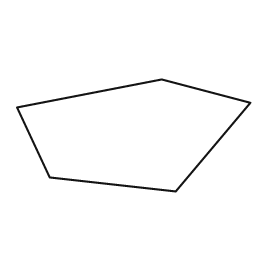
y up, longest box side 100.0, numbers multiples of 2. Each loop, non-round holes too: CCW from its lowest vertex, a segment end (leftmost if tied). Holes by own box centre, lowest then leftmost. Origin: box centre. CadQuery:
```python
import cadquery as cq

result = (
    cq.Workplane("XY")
    .moveTo(18.0, -24.0)
    .lineTo(50.0, 14.0)
    .lineTo(12.0, 24.0)
    .lineTo(-50.0, 12.0)
    .lineTo(-36.0, -18.0)
    .close()
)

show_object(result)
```